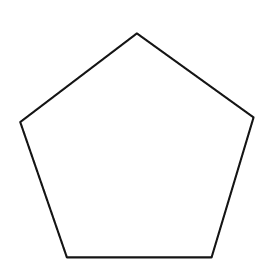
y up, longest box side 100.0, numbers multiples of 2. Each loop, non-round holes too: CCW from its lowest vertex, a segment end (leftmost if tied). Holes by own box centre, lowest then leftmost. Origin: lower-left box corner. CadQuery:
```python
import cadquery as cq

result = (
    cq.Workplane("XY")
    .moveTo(20.0, 0.0)
    .lineTo(82.0, 0.0)
    .lineTo(100.0, 60.0)
    .lineTo(50.0, 96.0)
    .lineTo(0.0, 58.0)
    .close()
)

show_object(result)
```